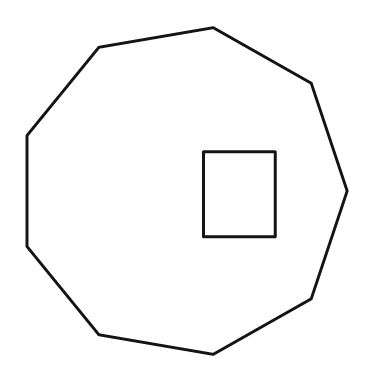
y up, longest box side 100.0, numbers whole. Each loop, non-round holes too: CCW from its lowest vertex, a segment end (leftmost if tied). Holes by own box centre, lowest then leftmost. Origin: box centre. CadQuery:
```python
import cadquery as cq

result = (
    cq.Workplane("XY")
    .moveTo(8.0, -50.0)
    .lineTo(38.0, -33.0)
    .lineTo(49.0, 0.0)
    .lineTo(38.0, 33.0)
    .lineTo(8.0, 50.0)
    .lineTo(-27.0, 44.0)
    .lineTo(-49.0, 17.0)
    .lineTo(-49.0, -17.0)
    .lineTo(-27.0, -44.0)
    .close()
    .moveTo(5.0, -14.0)
    .lineTo(27.0, -14.0)
    .lineTo(27.0, 12.0)
    .lineTo(5.0, 12.0)
    .close()
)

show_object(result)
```